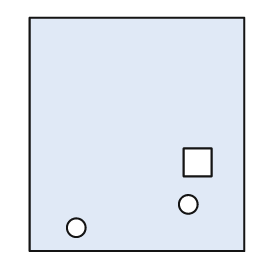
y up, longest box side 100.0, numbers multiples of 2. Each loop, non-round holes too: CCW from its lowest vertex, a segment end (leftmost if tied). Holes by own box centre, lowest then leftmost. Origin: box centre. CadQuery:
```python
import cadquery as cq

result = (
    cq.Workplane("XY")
    .moveTo(-46.0, -50.0)
    .lineTo(46.0, -50.0)
    .lineTo(46.0, 50.0)
    .lineTo(-46.0, 50.0)
    .close()
    .moveTo(-26.0, -40.0)
    .circle(4.0)
    .moveTo(22.0, -30.0)
    .circle(4.0)
    .moveTo(20.0, -18.0)
    .lineTo(32.0, -18.0)
    .lineTo(32.0, -6.0)
    .lineTo(20.0, -6.0)
    .close()
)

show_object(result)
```